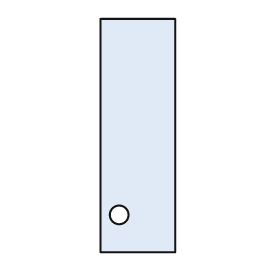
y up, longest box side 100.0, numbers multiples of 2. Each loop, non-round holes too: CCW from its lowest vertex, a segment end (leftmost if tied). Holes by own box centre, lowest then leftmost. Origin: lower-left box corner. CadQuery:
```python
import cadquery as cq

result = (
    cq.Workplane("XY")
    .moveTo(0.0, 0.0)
    .lineTo(32.0, 0.0)
    .lineTo(32.0, 100.0)
    .lineTo(0.0, 100.0)
    .close()
    .moveTo(8.0, 16.0)
    .circle(4.0)
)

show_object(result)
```